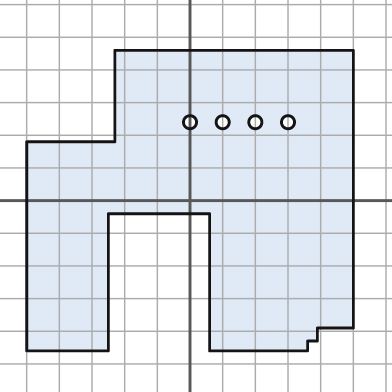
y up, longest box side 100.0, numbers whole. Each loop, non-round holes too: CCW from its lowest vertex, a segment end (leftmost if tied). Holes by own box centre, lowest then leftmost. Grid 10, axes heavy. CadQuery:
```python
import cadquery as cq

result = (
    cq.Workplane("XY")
    .moveTo(-50.0, -46.0)
    .lineTo(-25.0, -46.0)
    .lineTo(-25.0, -4.0)
    .lineTo(6.0, -4.0)
    .lineTo(6.0, -46.0)
    .lineTo(36.0, -46.0)
    .lineTo(36.0, -43.0)
    .lineTo(39.0, -43.0)
    .lineTo(39.0, -39.0)
    .lineTo(50.0, -39.0)
    .lineTo(50.0, 46.0)
    .lineTo(-23.0, 46.0)
    .lineTo(-23.0, 18.0)
    .lineTo(-50.0, 18.0)
    .close()
    .moveTo(0.0, 24.0)
    .circle(2.0)
    .moveTo(10.0, 24.0)
    .circle(2.0)
    .moveTo(20.0, 24.0)
    .circle(2.0)
    .moveTo(30.0, 24.0)
    .circle(2.0)
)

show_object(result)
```